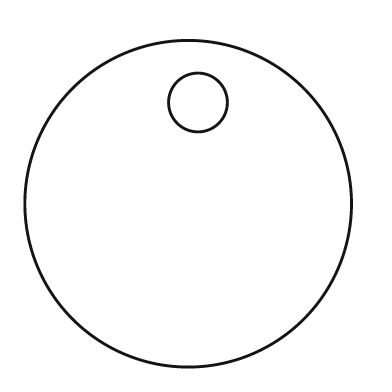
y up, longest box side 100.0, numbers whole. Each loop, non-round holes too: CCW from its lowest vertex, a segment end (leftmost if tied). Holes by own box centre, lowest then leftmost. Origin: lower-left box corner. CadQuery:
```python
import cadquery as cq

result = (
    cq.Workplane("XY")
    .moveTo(50.0, 50.0)
    .circle(50.0)
    .moveTo(53.0, 81.0)
    .circle(9.0)
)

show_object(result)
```